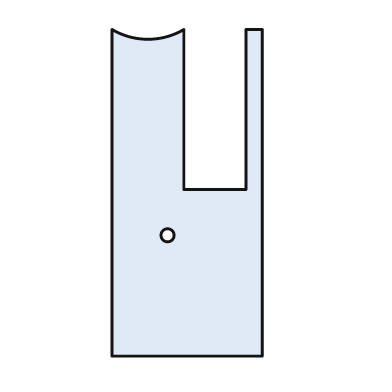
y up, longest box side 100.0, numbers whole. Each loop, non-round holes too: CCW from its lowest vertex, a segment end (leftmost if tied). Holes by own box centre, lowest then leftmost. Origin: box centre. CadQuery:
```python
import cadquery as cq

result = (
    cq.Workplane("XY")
    .moveTo(-23.0, -50.0)
    .lineTo(23.0, -50.0)
    .lineTo(23.0, 50.0)
    .lineTo(18.0, 50.0)
    .lineTo(18.0, 1.0)
    .lineTo(-1.0, 1.0)
    .lineTo(-1.0, 50.0)
    .threePointArc((-12.0, 47.0), (-23.0, 50.0))
    .close()
    .moveTo(-6.0, -13.0)
    .circle(2.0)
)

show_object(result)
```